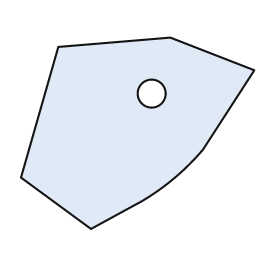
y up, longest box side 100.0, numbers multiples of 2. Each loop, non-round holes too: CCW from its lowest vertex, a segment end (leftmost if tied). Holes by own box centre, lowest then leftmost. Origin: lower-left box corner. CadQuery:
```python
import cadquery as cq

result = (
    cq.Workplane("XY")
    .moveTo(30.0, 0.0)
    .lineTo(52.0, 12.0)
    .threePointArc((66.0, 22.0), (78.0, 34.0))
    .lineTo(100.0, 68.0)
    .lineTo(64.0, 82.0)
    .lineTo(16.0, 78.0)
    .lineTo(0.0, 22.0)
    .close()
    .moveTo(56.0, 58.0)
    .circle(6.0)
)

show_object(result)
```